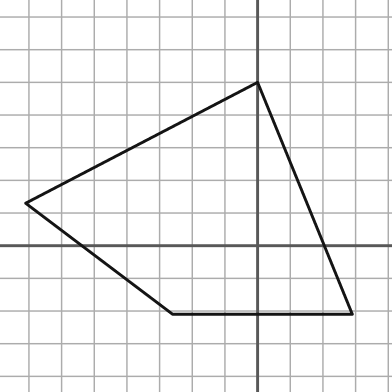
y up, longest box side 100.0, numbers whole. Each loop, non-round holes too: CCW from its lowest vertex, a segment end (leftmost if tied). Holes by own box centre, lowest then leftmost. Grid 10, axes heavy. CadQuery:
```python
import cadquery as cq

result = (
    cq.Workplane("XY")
    .moveTo(-26.0, -21.0)
    .lineTo(29.0, -21.0)
    .lineTo(0.0, 50.0)
    .lineTo(-71.0, 13.0)
    .close()
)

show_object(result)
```